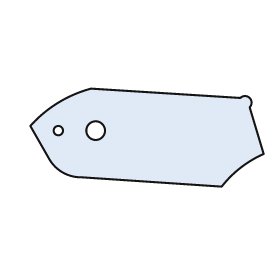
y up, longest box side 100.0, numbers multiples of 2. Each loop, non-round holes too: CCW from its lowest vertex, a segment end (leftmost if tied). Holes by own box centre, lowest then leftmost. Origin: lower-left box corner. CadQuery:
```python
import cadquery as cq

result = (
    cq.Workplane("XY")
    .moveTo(82.0, 0.0)
    .threePointArc((90.0, 8.0), (100.0, 14.0))
    .lineTo(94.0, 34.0)
    .threePointArc((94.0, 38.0), (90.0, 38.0))
    .lineTo(26.0, 42.0)
    .threePointArc((12.0, 36.0), (0.0, 26.0))
    .lineTo(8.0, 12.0)
    .threePointArc((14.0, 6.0), (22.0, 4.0))
    .close()
    .moveTo(12.0, 24.0)
    .circle(2.0)
    .moveTo(28.0, 24.0)
    .circle(4.0)
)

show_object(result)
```